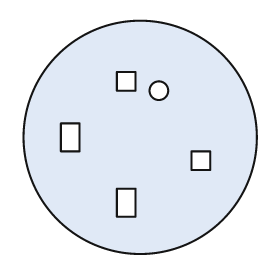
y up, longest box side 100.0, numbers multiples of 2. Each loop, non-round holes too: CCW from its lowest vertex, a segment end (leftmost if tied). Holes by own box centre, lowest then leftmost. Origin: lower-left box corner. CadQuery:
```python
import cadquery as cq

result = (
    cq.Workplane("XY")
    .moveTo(50.0, 50.0)
    .circle(50.0)
    .moveTo(40.0, 16.0)
    .lineTo(48.0, 16.0)
    .lineTo(48.0, 28.0)
    .lineTo(40.0, 28.0)
    .close()
    .moveTo(72.0, 36.0)
    .lineTo(80.0, 36.0)
    .lineTo(80.0, 44.0)
    .lineTo(72.0, 44.0)
    .close()
    .moveTo(16.0, 44.0)
    .lineTo(24.0, 44.0)
    .lineTo(24.0, 56.0)
    .lineTo(16.0, 56.0)
    .close()
    .moveTo(58.0, 70.0)
    .circle(4.0)
    .moveTo(40.0, 70.0)
    .lineTo(48.0, 70.0)
    .lineTo(48.0, 78.0)
    .lineTo(40.0, 78.0)
    .close()
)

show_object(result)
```